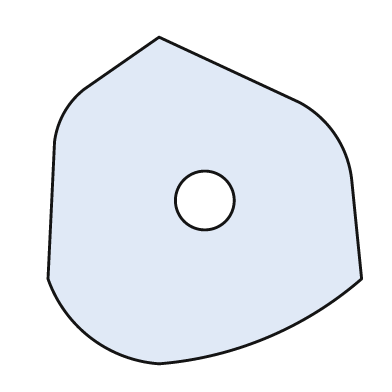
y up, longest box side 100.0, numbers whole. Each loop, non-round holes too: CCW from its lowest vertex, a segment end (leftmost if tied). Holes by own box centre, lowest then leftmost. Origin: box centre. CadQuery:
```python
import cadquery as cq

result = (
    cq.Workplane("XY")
    .moveTo(-14.0, -50.0)
    .threePointArc((19.0, -42.0), (48.0, -24.0))
    .lineTo(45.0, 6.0)
    .threePointArc((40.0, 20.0), (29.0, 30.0))
    .lineTo(-14.0, 50.0)
    .lineTo(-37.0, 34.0)
    .threePointArc((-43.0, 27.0), (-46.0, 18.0))
    .lineTo(-48.0, -24.0)
    .threePointArc((-35.0, -42.0), (-14.0, -50.0))
    .close()
    .moveTo(0.0, 0.0)
    .circle(9.0)
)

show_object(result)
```